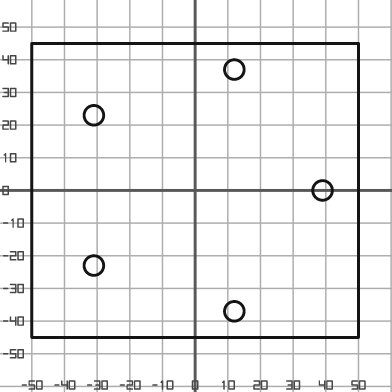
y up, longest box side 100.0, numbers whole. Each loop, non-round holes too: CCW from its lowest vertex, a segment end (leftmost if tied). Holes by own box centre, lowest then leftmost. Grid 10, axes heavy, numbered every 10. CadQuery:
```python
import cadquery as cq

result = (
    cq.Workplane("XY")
    .moveTo(-50.0, -45.0)
    .lineTo(50.0, -45.0)
    .lineTo(50.0, 45.0)
    .lineTo(-50.0, 45.0)
    .close()
    .moveTo(12.0, -37.0)
    .circle(3.0)
    .moveTo(-31.0, -23.0)
    .circle(3.0)
    .moveTo(39.0, 0.0)
    .circle(3.0)
    .moveTo(-31.0, 23.0)
    .circle(3.0)
    .moveTo(12.0, 37.0)
    .circle(3.0)
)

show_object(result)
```